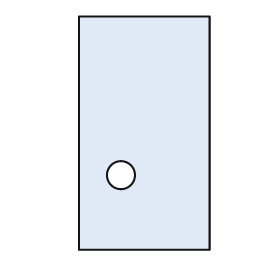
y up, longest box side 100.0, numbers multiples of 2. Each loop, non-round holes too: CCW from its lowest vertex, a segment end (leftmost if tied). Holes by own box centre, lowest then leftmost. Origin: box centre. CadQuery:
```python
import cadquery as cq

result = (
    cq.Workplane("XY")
    .moveTo(-28.0, -50.0)
    .lineTo(28.0, -50.0)
    .lineTo(28.0, 50.0)
    .lineTo(-28.0, 50.0)
    .close()
    .moveTo(-10.0, -18.0)
    .circle(6.0)
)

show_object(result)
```